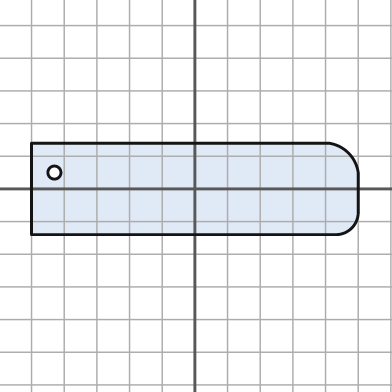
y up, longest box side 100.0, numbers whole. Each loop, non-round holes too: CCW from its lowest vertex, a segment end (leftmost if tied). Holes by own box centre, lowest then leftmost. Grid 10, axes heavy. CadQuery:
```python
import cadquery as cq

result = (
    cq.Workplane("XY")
    .moveTo(-50.0, -14.0)
    .lineTo(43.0, -14.0)
    .threePointArc((48.0, -12.0), (50.0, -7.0))
    .lineTo(50.0, 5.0)
    .threePointArc((47.0, 11.0), (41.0, 14.0))
    .lineTo(-50.0, 14.0)
    .close()
    .moveTo(-43.0, 5.0)
    .circle(2.0)
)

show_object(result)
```